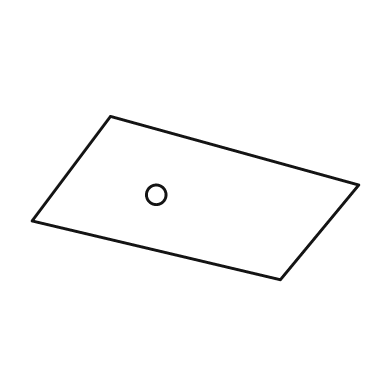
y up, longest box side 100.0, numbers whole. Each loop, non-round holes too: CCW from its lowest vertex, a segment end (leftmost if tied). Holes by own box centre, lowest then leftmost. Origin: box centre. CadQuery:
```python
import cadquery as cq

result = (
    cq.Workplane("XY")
    .moveTo(26.0, -25.0)
    .lineTo(50.0, 4.0)
    .lineTo(-26.0, 25.0)
    .lineTo(-50.0, -7.0)
    .close()
    .moveTo(-12.0, 1.0)
    .circle(3.0)
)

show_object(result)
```